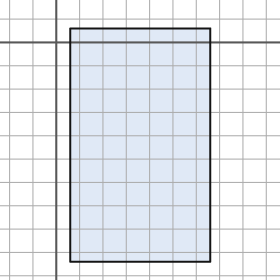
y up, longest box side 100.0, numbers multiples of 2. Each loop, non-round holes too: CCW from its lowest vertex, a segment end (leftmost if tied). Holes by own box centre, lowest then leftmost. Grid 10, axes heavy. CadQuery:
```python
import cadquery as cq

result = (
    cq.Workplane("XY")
    .moveTo(6.0, -94.0)
    .lineTo(66.0, -94.0)
    .lineTo(66.0, 6.0)
    .lineTo(6.0, 6.0)
    .close()
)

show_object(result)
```